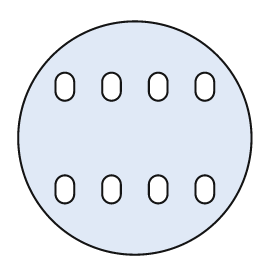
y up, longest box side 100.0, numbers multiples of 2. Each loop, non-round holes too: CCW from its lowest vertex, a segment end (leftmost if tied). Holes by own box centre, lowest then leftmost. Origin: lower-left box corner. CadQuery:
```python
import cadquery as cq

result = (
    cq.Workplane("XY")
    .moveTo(50.0, 50.0)
    .circle(50.0)
    .moveTo(16.0, 26.0)
    .threePointArc((20.0, 22.0), (24.0, 26.0))
    .lineTo(24.0, 30.0)
    .threePointArc((20.0, 34.0), (16.0, 30.0))
    .close()
    .moveTo(36.0, 26.0)
    .threePointArc((40.0, 22.0), (44.0, 26.0))
    .lineTo(44.0, 30.0)
    .threePointArc((40.0, 34.0), (36.0, 30.0))
    .close()
    .moveTo(56.0, 26.0)
    .threePointArc((60.0, 22.0), (64.0, 26.0))
    .lineTo(64.0, 30.0)
    .threePointArc((60.0, 34.0), (56.0, 30.0))
    .close()
    .moveTo(76.0, 26.0)
    .threePointArc((80.0, 22.0), (84.0, 26.0))
    .lineTo(84.0, 30.0)
    .threePointArc((80.0, 34.0), (76.0, 30.0))
    .close()
    .moveTo(16.0, 70.0)
    .threePointArc((20.0, 66.0), (24.0, 70.0))
    .lineTo(24.0, 74.0)
    .threePointArc((20.0, 78.0), (16.0, 74.0))
    .close()
    .moveTo(36.0, 70.0)
    .threePointArc((40.0, 66.0), (44.0, 70.0))
    .lineTo(44.0, 74.0)
    .threePointArc((40.0, 78.0), (36.0, 74.0))
    .close()
    .moveTo(56.0, 70.0)
    .threePointArc((60.0, 66.0), (64.0, 70.0))
    .lineTo(64.0, 74.0)
    .threePointArc((60.0, 78.0), (56.0, 74.0))
    .close()
    .moveTo(76.0, 70.0)
    .threePointArc((80.0, 66.0), (84.0, 70.0))
    .lineTo(84.0, 74.0)
    .threePointArc((80.0, 78.0), (76.0, 74.0))
    .close()
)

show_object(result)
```